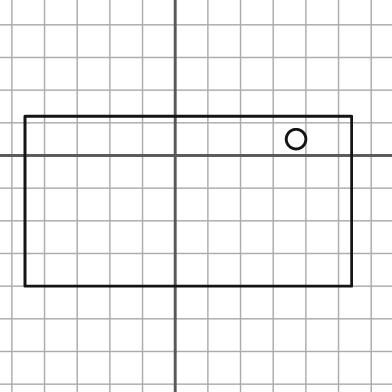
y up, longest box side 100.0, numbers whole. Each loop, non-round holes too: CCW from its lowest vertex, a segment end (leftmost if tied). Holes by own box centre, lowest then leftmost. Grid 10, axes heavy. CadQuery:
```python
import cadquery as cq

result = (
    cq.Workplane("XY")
    .moveTo(-46.0, -40.0)
    .lineTo(54.0, -40.0)
    .lineTo(54.0, 12.0)
    .lineTo(-46.0, 12.0)
    .close()
    .moveTo(37.0, 5.0)
    .circle(3.0)
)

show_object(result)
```